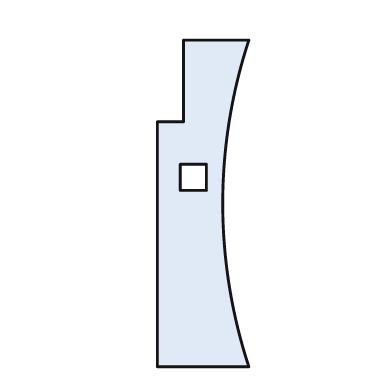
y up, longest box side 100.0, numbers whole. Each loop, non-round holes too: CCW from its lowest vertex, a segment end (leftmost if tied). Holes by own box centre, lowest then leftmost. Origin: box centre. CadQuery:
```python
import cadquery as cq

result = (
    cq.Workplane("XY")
    .moveTo(-14.0, -50.0)
    .lineTo(14.0, -50.0)
    .threePointArc((6.0, 0.0), (14.0, 50.0))
    .lineTo(-6.0, 50.0)
    .lineTo(-6.0, 25.0)
    .lineTo(-14.0, 25.0)
    .close()
    .moveTo(-7.0, 4.0)
    .lineTo(1.0, 4.0)
    .lineTo(1.0, 12.0)
    .lineTo(-7.0, 12.0)
    .close()
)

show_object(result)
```